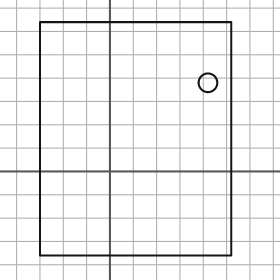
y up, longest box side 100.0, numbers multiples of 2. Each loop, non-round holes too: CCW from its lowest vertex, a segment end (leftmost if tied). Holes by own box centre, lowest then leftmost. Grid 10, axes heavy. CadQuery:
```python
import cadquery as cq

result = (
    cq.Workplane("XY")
    .moveTo(-30.0, -36.0)
    .lineTo(52.0, -36.0)
    .lineTo(52.0, 64.0)
    .lineTo(-30.0, 64.0)
    .close()
    .moveTo(42.0, 38.0)
    .circle(4.0)
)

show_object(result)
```